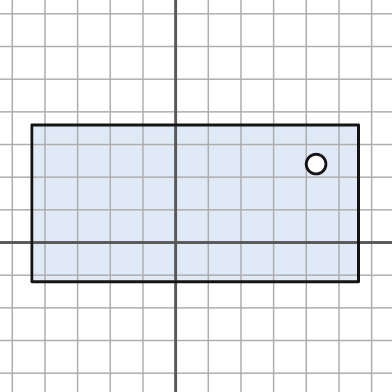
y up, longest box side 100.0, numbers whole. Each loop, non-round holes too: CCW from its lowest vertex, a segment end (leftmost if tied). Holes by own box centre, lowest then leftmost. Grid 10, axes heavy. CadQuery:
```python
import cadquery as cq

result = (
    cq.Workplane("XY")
    .moveTo(-44.0, -12.0)
    .lineTo(56.0, -12.0)
    .lineTo(56.0, 36.0)
    .lineTo(-44.0, 36.0)
    .close()
    .moveTo(43.0, 24.0)
    .circle(3.0)
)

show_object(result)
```